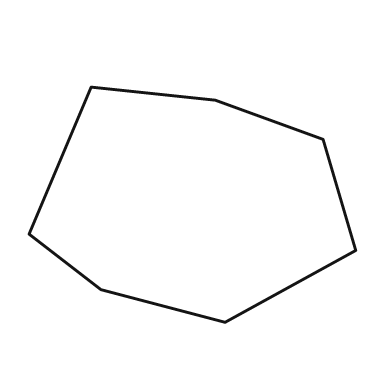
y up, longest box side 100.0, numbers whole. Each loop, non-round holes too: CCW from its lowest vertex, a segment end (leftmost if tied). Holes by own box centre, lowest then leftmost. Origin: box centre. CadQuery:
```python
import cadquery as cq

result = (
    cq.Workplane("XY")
    .moveTo(10.0, -36.0)
    .lineTo(50.0, -14.0)
    .lineTo(40.0, 20.0)
    .lineTo(7.0, 32.0)
    .lineTo(-31.0, 36.0)
    .lineTo(-50.0, -9.0)
    .lineTo(-28.0, -26.0)
    .close()
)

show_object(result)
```